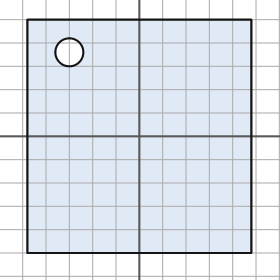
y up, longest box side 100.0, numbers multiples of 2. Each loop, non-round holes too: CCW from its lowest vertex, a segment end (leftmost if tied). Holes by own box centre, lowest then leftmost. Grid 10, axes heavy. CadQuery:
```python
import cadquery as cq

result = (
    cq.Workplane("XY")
    .moveTo(-48.0, -50.0)
    .lineTo(48.0, -50.0)
    .lineTo(48.0, 50.0)
    .lineTo(-48.0, 50.0)
    .close()
    .moveTo(-30.0, 36.0)
    .circle(6.0)
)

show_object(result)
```